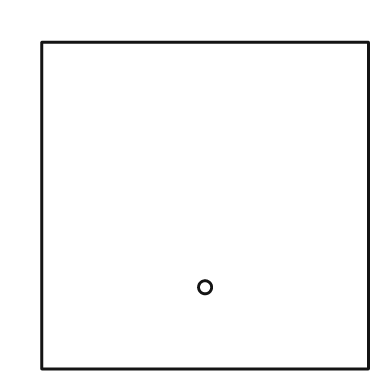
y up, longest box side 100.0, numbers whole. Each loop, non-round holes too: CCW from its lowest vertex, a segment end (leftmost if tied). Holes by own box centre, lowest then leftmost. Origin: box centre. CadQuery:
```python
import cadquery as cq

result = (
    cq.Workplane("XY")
    .moveTo(-50.0, -50.0)
    .lineTo(50.0, -50.0)
    .lineTo(50.0, 50.0)
    .lineTo(-50.0, 50.0)
    .close()
    .moveTo(0.0, -25.0)
    .circle(2.0)
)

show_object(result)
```